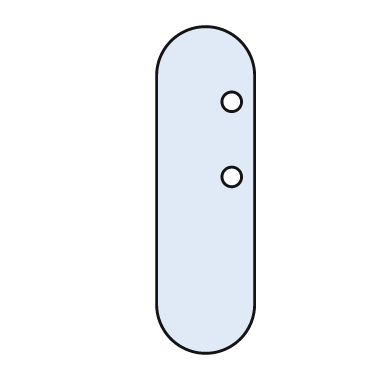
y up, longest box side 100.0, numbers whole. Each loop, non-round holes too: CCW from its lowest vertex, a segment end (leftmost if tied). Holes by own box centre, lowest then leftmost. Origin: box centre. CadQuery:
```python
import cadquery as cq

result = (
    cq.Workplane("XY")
    .moveTo(-15.0, -35.0)
    .threePointArc((0.0, -50.0), (15.0, -35.0))
    .lineTo(15.0, 35.0)
    .threePointArc((0.0, 50.0), (-15.0, 35.0))
    .close()
    .moveTo(8.0, 4.0)
    .circle(3.0)
    .moveTo(8.0, 27.0)
    .circle(3.0)
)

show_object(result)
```